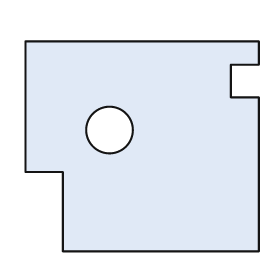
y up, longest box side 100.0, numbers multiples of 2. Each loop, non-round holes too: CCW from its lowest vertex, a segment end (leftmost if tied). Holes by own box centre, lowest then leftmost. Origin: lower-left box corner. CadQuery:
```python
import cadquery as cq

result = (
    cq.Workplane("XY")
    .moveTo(16.0, 0.0)
    .lineTo(100.0, 0.0)
    .lineTo(100.0, 66.0)
    .lineTo(88.0, 66.0)
    .lineTo(88.0, 80.0)
    .lineTo(100.0, 80.0)
    .lineTo(100.0, 90.0)
    .lineTo(0.0, 90.0)
    .lineTo(0.0, 34.0)
    .lineTo(16.0, 34.0)
    .close()
    .moveTo(36.0, 52.0)
    .circle(10.0)
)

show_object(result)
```